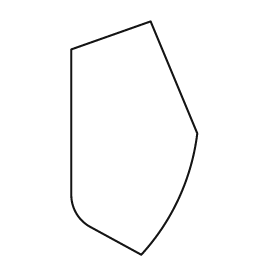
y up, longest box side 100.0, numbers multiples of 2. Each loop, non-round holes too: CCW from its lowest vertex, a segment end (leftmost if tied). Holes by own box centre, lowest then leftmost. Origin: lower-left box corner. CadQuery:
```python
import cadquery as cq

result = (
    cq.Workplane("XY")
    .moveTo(30.0, 0.0)
    .threePointArc((46.0, 24.0), (54.0, 52.0))
    .lineTo(34.0, 100.0)
    .lineTo(0.0, 88.0)
    .lineTo(0.0, 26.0)
    .threePointArc((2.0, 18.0), (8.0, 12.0))
    .close()
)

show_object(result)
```